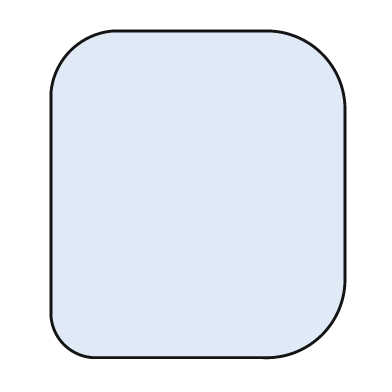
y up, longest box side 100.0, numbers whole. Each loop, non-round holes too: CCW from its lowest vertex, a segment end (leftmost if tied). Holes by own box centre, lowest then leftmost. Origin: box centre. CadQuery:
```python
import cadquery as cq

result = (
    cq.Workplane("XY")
    .moveTo(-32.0, -50.0)
    .lineTo(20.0, -50.0)
    .threePointArc((38.0, -43.0), (45.0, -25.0))
    .lineTo(45.0, 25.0)
    .threePointArc((38.0, 43.0), (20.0, 50.0))
    .lineTo(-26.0, 50.0)
    .threePointArc((-39.0, 44.0), (-45.0, 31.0))
    .lineTo(-45.0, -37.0)
    .threePointArc((-41.0, -46.0), (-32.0, -50.0))
    .close()
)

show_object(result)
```